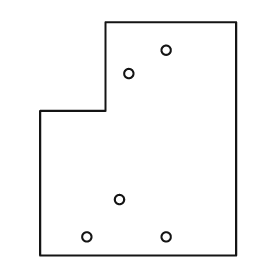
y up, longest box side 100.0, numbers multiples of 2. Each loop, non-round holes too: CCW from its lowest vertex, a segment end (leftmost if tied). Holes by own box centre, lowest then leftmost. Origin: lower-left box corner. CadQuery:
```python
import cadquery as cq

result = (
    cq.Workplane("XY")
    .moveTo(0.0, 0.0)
    .lineTo(84.0, 0.0)
    .lineTo(84.0, 100.0)
    .lineTo(28.0, 100.0)
    .lineTo(28.0, 62.0)
    .lineTo(0.0, 62.0)
    .close()
    .moveTo(20.0, 8.0)
    .circle(2.0)
    .moveTo(54.0, 8.0)
    .circle(2.0)
    .moveTo(34.0, 24.0)
    .circle(2.0)
    .moveTo(38.0, 78.0)
    .circle(2.0)
    .moveTo(54.0, 88.0)
    .circle(2.0)
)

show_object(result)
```